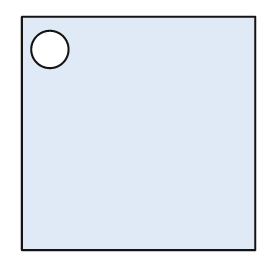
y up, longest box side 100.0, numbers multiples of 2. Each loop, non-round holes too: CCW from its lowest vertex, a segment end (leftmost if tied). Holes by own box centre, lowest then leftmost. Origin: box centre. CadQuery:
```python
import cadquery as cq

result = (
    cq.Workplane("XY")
    .moveTo(-50.0, -50.0)
    .lineTo(50.0, -50.0)
    .lineTo(50.0, 50.0)
    .lineTo(-50.0, 50.0)
    .close()
    .moveTo(-38.0, 36.0)
    .circle(8.0)
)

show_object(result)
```